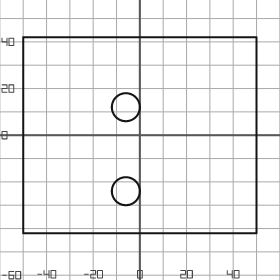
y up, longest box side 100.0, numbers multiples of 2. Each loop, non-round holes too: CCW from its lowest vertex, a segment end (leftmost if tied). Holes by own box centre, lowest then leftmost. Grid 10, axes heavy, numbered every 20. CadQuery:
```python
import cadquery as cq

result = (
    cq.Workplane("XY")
    .moveTo(-50.0, -42.0)
    .lineTo(50.0, -42.0)
    .lineTo(50.0, 42.0)
    .lineTo(-50.0, 42.0)
    .close()
    .moveTo(-6.0, -24.0)
    .circle(6.0)
    .moveTo(-6.0, 12.0)
    .circle(6.0)
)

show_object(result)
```